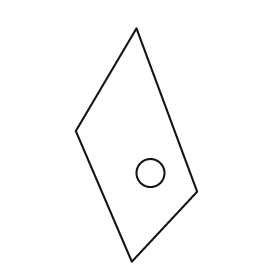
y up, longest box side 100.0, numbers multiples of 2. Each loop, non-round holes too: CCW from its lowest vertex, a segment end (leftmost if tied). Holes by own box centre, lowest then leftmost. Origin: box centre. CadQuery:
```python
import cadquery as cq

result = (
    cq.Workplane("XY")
    .moveTo(-2.0, -50.0)
    .lineTo(26.0, -20.0)
    .lineTo(0.0, 50.0)
    .lineTo(-26.0, 6.0)
    .close()
    .moveTo(6.0, -12.0)
    .circle(6.0)
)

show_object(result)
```